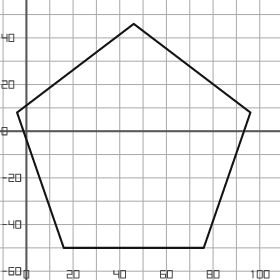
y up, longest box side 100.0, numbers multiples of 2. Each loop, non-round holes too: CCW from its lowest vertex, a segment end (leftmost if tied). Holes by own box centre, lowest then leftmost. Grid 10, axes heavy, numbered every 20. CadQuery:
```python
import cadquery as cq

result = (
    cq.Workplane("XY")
    .moveTo(16.0, -50.0)
    .lineTo(76.0, -50.0)
    .lineTo(96.0, 8.0)
    .lineTo(46.0, 46.0)
    .lineTo(-4.0, 8.0)
    .close()
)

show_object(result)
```